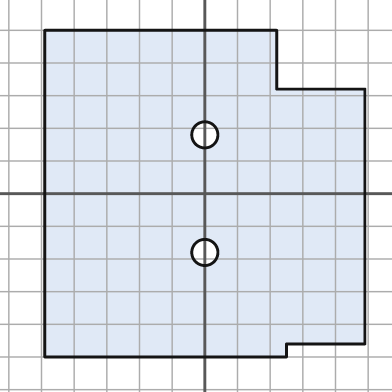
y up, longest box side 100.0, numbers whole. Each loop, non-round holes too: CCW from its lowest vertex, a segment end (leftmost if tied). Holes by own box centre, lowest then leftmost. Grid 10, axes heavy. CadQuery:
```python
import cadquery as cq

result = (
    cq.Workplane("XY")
    .moveTo(-49.0, -50.0)
    .lineTo(25.0, -50.0)
    .lineTo(25.0, -46.0)
    .lineTo(49.0, -46.0)
    .lineTo(49.0, 32.0)
    .lineTo(22.0, 32.0)
    .lineTo(22.0, 50.0)
    .lineTo(-49.0, 50.0)
    .close()
    .moveTo(0.0, -18.0)
    .circle(4.0)
    .moveTo(0.0, 18.0)
    .circle(4.0)
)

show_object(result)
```